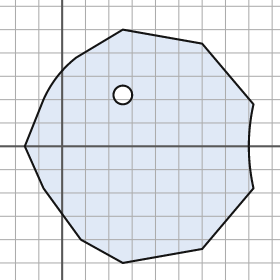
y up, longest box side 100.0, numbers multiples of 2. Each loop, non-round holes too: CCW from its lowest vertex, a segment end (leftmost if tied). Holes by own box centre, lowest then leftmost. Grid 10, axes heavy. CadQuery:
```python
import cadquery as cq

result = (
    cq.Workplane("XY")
    .moveTo(26.0, -50.0)
    .lineTo(60.0, -44.0)
    .lineTo(82.0, -18.0)
    .threePointArc((80.0, 0.0), (82.0, 18.0))
    .lineTo(60.0, 44.0)
    .lineTo(26.0, 50.0)
    .lineTo(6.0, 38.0)
    .threePointArc((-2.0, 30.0), (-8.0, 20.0))
    .lineTo(-16.0, 0.0)
    .lineTo(-8.0, -18.0)
    .lineTo(8.0, -40.0)
    .close()
    .moveTo(26.0, 22.0)
    .circle(4.0)
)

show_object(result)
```